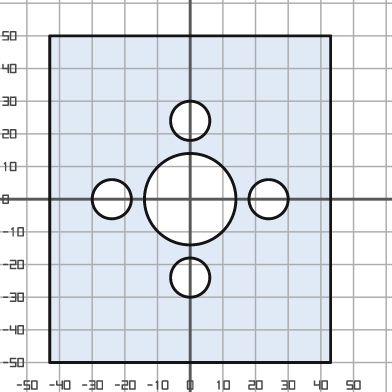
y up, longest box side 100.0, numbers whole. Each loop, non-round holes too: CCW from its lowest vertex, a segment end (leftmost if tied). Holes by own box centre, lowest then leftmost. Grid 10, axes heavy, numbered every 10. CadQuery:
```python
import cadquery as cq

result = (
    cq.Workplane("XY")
    .moveTo(-43.0, -50.0)
    .lineTo(43.0, -50.0)
    .lineTo(43.0, 50.0)
    .lineTo(-43.0, 50.0)
    .close()
    .moveTo(0.0, -24.0)
    .circle(6.0)
    .moveTo(-24.0, 0.0)
    .circle(6.0)
    .moveTo(0.0, 0.0)
    .circle(14.0)
    .moveTo(24.0, 0.0)
    .circle(6.0)
    .moveTo(0.0, 24.0)
    .circle(6.0)
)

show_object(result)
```